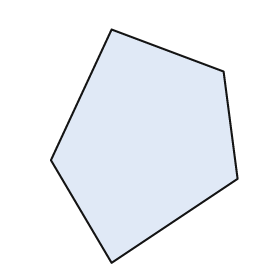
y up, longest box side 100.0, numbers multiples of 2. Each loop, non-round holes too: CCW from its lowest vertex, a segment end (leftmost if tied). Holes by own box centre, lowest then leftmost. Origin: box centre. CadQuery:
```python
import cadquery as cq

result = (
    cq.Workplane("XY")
    .moveTo(-14.0, -50.0)
    .lineTo(40.0, -14.0)
    .lineTo(34.0, 32.0)
    .lineTo(-14.0, 50.0)
    .lineTo(-40.0, -6.0)
    .close()
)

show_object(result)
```